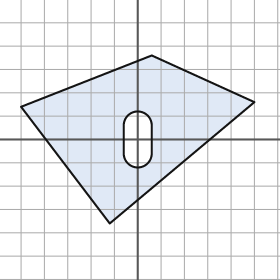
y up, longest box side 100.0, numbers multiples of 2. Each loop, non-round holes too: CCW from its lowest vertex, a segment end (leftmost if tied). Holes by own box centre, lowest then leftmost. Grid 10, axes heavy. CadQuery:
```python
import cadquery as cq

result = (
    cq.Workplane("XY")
    .moveTo(-12.0, -36.0)
    .lineTo(50.0, 16.0)
    .lineTo(6.0, 36.0)
    .lineTo(-50.0, 14.0)
    .close()
    .moveTo(-6.0, -6.0)
    .threePointArc((0.0, -12.0), (6.0, -6.0))
    .lineTo(6.0, 6.0)
    .threePointArc((0.0, 12.0), (-6.0, 6.0))
    .close()
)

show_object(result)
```